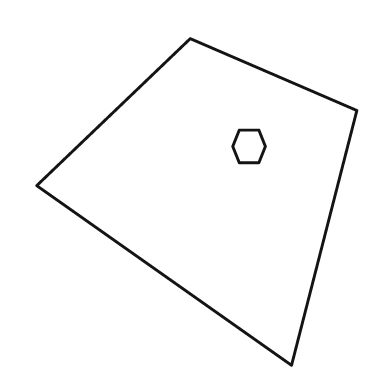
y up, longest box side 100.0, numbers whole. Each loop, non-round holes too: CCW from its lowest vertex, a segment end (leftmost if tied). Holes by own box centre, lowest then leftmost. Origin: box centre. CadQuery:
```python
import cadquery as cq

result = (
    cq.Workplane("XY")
    .moveTo(29.0, -50.0)
    .lineTo(49.0, 28.0)
    .lineTo(-2.0, 50.0)
    .lineTo(-49.0, 5.0)
    .close()
    .moveTo(13.0, 12.0)
    .lineTo(19.0, 12.0)
    .lineTo(21.0, 17.0)
    .lineTo(19.0, 22.0)
    .lineTo(13.0, 22.0)
    .lineTo(11.0, 17.0)
    .close()
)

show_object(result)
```